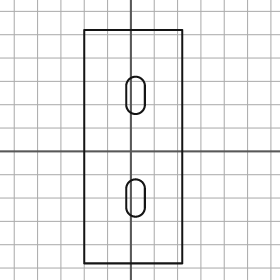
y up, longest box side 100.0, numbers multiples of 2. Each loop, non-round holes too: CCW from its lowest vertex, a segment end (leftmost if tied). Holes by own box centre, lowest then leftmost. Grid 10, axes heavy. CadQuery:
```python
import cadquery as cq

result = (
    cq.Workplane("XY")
    .moveTo(-20.0, -48.0)
    .lineTo(22.0, -48.0)
    .lineTo(22.0, 52.0)
    .lineTo(-20.0, 52.0)
    .close()
    .moveTo(-2.0, -24.0)
    .threePointArc((2.0, -28.0), (6.0, -24.0))
    .lineTo(6.0, -16.0)
    .threePointArc((2.0, -12.0), (-2.0, -16.0))
    .close()
    .moveTo(-2.0, 20.0)
    .threePointArc((2.0, 16.0), (6.0, 20.0))
    .lineTo(6.0, 28.0)
    .threePointArc((2.0, 32.0), (-2.0, 28.0))
    .close()
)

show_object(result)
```